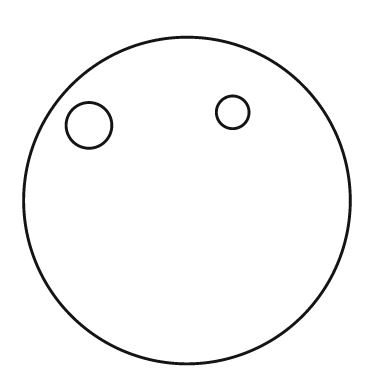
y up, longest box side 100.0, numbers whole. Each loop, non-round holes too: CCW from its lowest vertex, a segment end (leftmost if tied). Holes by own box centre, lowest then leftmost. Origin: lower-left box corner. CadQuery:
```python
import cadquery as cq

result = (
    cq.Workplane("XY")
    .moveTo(50.0, 50.0)
    .circle(50.0)
    .moveTo(20.0, 73.0)
    .circle(7.0)
    .moveTo(64.0, 77.0)
    .circle(5.0)
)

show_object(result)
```